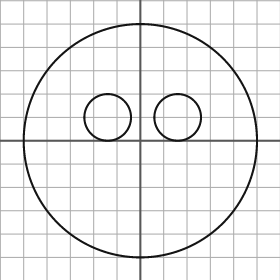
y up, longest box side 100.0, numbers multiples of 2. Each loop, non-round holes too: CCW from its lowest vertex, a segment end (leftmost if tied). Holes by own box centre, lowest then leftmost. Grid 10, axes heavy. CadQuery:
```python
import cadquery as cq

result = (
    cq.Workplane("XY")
    .moveTo(0.0, 0.0)
    .circle(50.0)
    .moveTo(-14.0, 10.0)
    .circle(10.0)
    .moveTo(16.0, 10.0)
    .circle(10.0)
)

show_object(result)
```